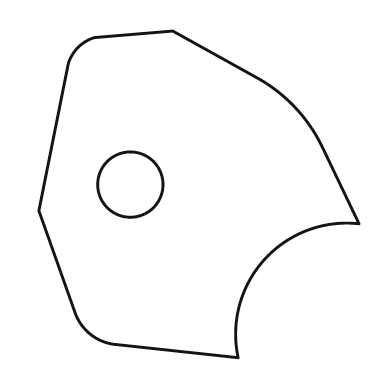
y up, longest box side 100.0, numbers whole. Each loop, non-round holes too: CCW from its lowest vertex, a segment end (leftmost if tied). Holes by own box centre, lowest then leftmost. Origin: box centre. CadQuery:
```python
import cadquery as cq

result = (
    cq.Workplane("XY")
    .moveTo(12.0, -50.0)
    .threePointArc((20.0, -20.0), (49.0, -9.0))
    .lineTo(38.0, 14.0)
    .threePointArc((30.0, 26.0), (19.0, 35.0))
    .lineTo(-8.0, 50.0)
    .lineTo(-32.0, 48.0)
    .threePointArc((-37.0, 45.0), (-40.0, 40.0))
    .lineTo(-49.0, -5.0)
    .lineTo(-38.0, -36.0)
    .threePointArc((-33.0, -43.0), (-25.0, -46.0))
    .close()
    .moveTo(-21.0, 3.0)
    .circle(10.0)
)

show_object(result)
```